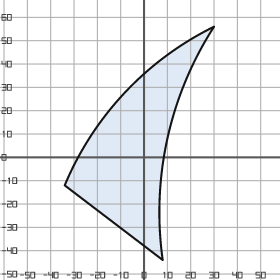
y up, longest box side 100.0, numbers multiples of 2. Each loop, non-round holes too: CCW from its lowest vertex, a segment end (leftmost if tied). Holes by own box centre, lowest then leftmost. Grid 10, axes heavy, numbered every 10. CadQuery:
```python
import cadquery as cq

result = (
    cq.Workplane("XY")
    .moveTo(8.0, -44.0)
    .threePointArc((10.0, 8.0), (30.0, 56.0))
    .threePointArc((-8.0, 28.0), (-34.0, -12.0))
    .close()
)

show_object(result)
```